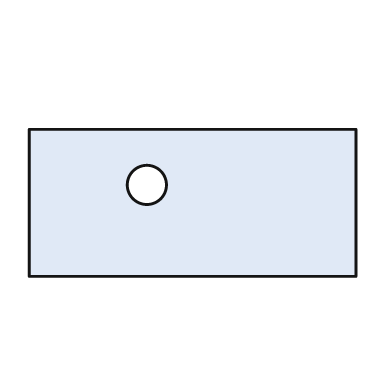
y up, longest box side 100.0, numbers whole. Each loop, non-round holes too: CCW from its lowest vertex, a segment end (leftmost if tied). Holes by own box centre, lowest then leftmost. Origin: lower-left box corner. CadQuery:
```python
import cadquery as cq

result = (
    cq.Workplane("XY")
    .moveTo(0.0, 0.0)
    .lineTo(100.0, 0.0)
    .lineTo(100.0, 45.0)
    .lineTo(0.0, 45.0)
    .close()
    .moveTo(36.0, 28.0)
    .circle(6.0)
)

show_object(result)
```